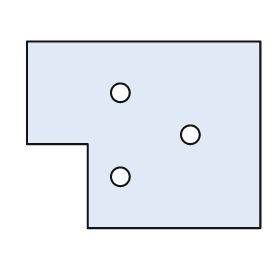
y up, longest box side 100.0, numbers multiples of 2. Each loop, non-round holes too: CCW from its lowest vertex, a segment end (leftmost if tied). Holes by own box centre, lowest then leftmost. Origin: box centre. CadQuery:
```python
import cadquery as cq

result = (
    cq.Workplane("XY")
    .moveTo(-24.0, -40.0)
    .lineTo(50.0, -40.0)
    .lineTo(50.0, 40.0)
    .lineTo(-50.0, 40.0)
    .lineTo(-50.0, -4.0)
    .lineTo(-24.0, -4.0)
    .close()
    .moveTo(-10.0, -18.0)
    .circle(4.0)
    .moveTo(20.0, 0.0)
    .circle(4.0)
    .moveTo(-10.0, 18.0)
    .circle(4.0)
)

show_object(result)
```